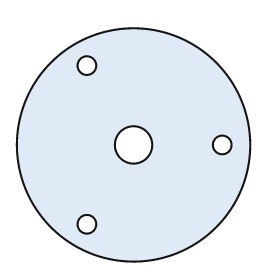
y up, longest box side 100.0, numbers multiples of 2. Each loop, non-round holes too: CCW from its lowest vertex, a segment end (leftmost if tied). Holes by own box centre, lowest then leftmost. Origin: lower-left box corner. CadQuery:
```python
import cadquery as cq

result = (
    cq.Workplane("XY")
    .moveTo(50.0, 50.0)
    .circle(50.0)
    .moveTo(30.0, 16.0)
    .circle(4.0)
    .moveTo(50.0, 50.0)
    .circle(8.0)
    .moveTo(88.0, 50.0)
    .circle(4.0)
    .moveTo(30.0, 84.0)
    .circle(4.0)
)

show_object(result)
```